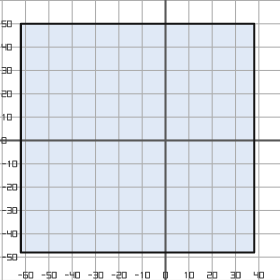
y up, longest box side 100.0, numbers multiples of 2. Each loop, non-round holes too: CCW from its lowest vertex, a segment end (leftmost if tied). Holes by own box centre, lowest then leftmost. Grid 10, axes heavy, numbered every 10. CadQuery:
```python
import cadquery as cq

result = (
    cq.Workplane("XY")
    .moveTo(-62.0, -48.0)
    .lineTo(38.0, -48.0)
    .lineTo(38.0, 50.0)
    .lineTo(-62.0, 50.0)
    .close()
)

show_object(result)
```